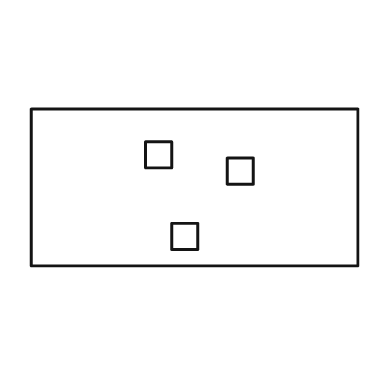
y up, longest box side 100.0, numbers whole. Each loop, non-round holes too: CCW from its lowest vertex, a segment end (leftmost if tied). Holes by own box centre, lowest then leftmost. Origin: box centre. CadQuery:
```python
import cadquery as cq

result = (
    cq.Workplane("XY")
    .moveTo(-50.0, -24.0)
    .lineTo(50.0, -24.0)
    .lineTo(50.0, 24.0)
    .lineTo(-50.0, 24.0)
    .close()
    .moveTo(-7.0, -19.0)
    .lineTo(1.0, -19.0)
    .lineTo(1.0, -11.0)
    .lineTo(-7.0, -11.0)
    .close()
    .moveTo(10.0, 1.0)
    .lineTo(18.0, 1.0)
    .lineTo(18.0, 9.0)
    .lineTo(10.0, 9.0)
    .close()
    .moveTo(-15.0, 6.0)
    .lineTo(-7.0, 6.0)
    .lineTo(-7.0, 14.0)
    .lineTo(-15.0, 14.0)
    .close()
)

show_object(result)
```